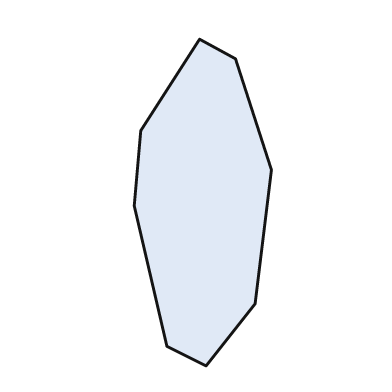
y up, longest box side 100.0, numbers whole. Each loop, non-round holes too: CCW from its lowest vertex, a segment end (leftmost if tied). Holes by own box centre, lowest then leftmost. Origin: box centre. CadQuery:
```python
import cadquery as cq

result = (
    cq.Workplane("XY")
    .moveTo(1.0, -50.0)
    .lineTo(16.0, -31.0)
    .lineTo(21.0, 10.0)
    .lineTo(10.0, 44.0)
    .lineTo(-1.0, 50.0)
    .lineTo(-19.0, 22.0)
    .lineTo(-21.0, -1.0)
    .lineTo(-11.0, -44.0)
    .close()
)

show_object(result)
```